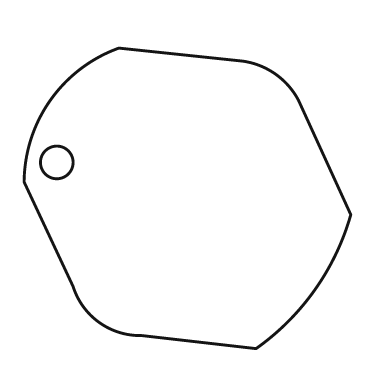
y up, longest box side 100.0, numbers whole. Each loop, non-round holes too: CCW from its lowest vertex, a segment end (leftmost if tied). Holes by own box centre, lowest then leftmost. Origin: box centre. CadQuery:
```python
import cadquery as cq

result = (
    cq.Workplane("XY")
    .moveTo(21.0, -46.0)
    .threePointArc((39.0, -28.0), (50.0, -5.0))
    .lineTo(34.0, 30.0)
    .threePointArc((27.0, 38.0), (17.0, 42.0))
    .lineTo(-21.0, 46.0)
    .threePointArc((-42.0, 30.0), (-50.0, 5.0))
    .lineTo(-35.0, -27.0)
    .threePointArc((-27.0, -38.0), (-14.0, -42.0))
    .close()
    .moveTo(-40.0, 11.0)
    .circle(5.0)
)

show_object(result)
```